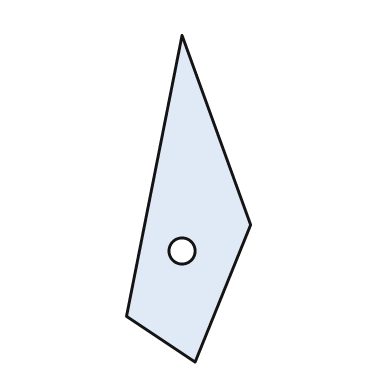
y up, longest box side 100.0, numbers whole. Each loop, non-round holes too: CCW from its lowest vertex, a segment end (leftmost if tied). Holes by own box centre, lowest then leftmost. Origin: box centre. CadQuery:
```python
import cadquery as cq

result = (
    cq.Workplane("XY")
    .moveTo(2.0, -50.0)
    .lineTo(19.0, -8.0)
    .lineTo(-2.0, 50.0)
    .lineTo(-19.0, -36.0)
    .close()
    .moveTo(-2.0, -16.0)
    .circle(4.0)
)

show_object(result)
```